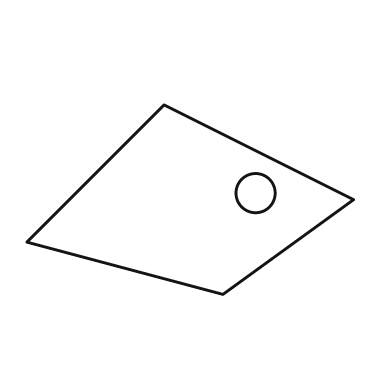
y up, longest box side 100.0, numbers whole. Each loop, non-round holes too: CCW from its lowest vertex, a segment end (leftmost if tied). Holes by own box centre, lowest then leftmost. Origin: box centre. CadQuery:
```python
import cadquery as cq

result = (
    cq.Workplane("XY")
    .moveTo(10.0, -29.0)
    .lineTo(50.0, 0.0)
    .lineTo(-8.0, 29.0)
    .lineTo(-50.0, -13.0)
    .close()
    .moveTo(20.0, 2.0)
    .circle(6.0)
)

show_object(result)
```